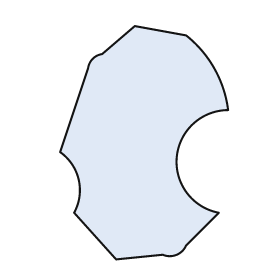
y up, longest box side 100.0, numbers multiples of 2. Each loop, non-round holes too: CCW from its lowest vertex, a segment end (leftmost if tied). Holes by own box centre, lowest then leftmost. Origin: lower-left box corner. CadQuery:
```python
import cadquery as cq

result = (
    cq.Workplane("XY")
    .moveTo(24.0, 0.0)
    .lineTo(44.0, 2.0)
    .threePointArc((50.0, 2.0), (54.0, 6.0))
    .lineTo(68.0, 20.0)
    .threePointArc((50.0, 44.0), (72.0, 64.0))
    .threePointArc((66.0, 82.0), (54.0, 96.0))
    .lineTo(32.0, 100.0)
    .lineTo(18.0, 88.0)
    .threePointArc((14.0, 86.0), (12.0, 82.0))
    .lineTo(0.0, 46.0)
    .threePointArc((8.0, 34.0), (6.0, 20.0))
    .close()
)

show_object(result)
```